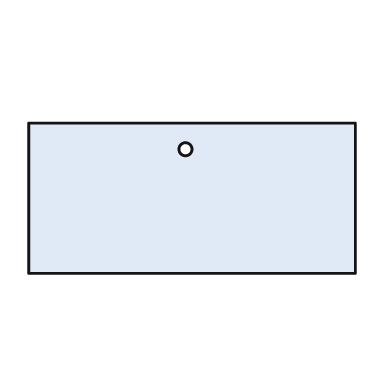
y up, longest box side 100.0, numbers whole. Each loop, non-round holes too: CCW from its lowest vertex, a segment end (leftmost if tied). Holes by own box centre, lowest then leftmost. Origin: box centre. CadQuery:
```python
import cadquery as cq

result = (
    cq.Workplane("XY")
    .moveTo(-50.0, -23.0)
    .lineTo(50.0, -23.0)
    .lineTo(50.0, 23.0)
    .lineTo(-50.0, 23.0)
    .close()
    .moveTo(-2.0, 15.0)
    .circle(2.0)
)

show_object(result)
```